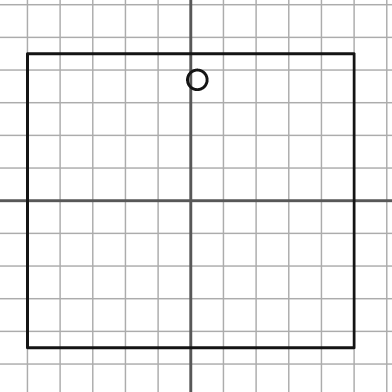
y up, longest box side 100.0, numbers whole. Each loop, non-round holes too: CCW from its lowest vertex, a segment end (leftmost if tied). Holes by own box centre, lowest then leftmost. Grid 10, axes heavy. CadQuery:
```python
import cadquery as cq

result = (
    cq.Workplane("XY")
    .moveTo(-50.0, -45.0)
    .lineTo(50.0, -45.0)
    .lineTo(50.0, 45.0)
    .lineTo(-50.0, 45.0)
    .close()
    .moveTo(2.0, 37.0)
    .circle(3.0)
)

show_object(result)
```